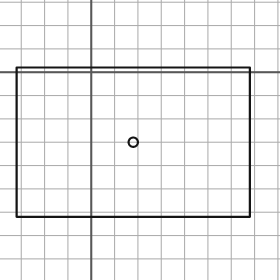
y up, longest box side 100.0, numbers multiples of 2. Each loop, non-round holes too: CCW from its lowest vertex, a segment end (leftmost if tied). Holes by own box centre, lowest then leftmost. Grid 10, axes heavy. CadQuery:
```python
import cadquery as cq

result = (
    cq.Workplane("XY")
    .moveTo(-32.0, -62.0)
    .lineTo(68.0, -62.0)
    .lineTo(68.0, 2.0)
    .lineTo(-32.0, 2.0)
    .close()
    .moveTo(18.0, -30.0)
    .circle(2.0)
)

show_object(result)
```